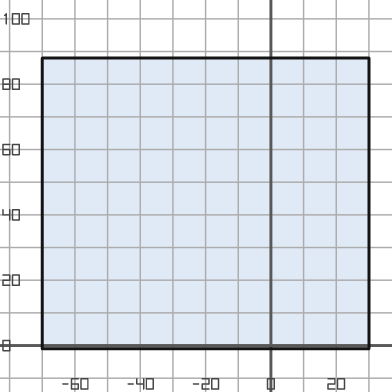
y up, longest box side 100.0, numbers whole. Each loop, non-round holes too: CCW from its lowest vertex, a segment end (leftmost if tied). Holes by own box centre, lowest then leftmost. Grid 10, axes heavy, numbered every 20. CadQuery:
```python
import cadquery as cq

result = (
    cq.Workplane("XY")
    .moveTo(-70.0, -1.0)
    .lineTo(30.0, -1.0)
    .lineTo(30.0, 88.0)
    .lineTo(-70.0, 88.0)
    .close()
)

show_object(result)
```